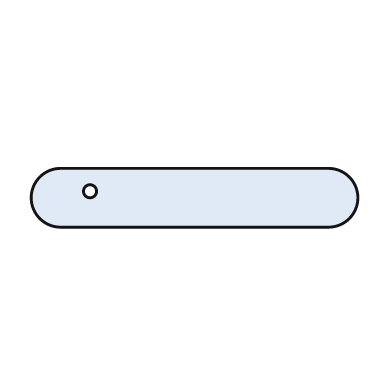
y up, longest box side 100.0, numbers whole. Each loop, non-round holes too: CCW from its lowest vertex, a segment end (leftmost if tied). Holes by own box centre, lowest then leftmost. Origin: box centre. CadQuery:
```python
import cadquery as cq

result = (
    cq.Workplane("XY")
    .moveTo(-41.0, -9.0)
    .lineTo(41.0, -9.0)
    .threePointArc((50.0, 0.0), (41.0, 9.0))
    .lineTo(-41.0, 9.0)
    .threePointArc((-50.0, 0.0), (-41.0, -9.0))
    .close()
    .moveTo(-32.0, 2.0)
    .circle(2.0)
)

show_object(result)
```